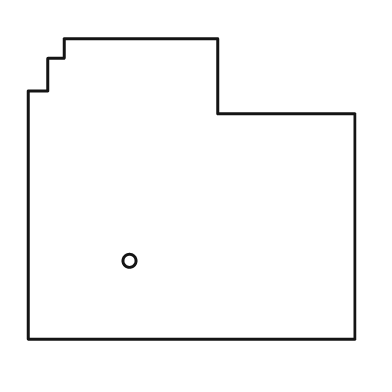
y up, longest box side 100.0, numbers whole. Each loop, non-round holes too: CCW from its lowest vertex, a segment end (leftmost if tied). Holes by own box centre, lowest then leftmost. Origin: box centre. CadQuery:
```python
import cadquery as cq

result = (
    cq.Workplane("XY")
    .moveTo(-50.0, -46.0)
    .lineTo(50.0, -46.0)
    .lineTo(50.0, 23.0)
    .lineTo(8.0, 23.0)
    .lineTo(8.0, 46.0)
    .lineTo(-39.0, 46.0)
    .lineTo(-39.0, 40.0)
    .lineTo(-44.0, 40.0)
    .lineTo(-44.0, 30.0)
    .lineTo(-50.0, 30.0)
    .close()
    .moveTo(-19.0, -22.0)
    .circle(2.0)
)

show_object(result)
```